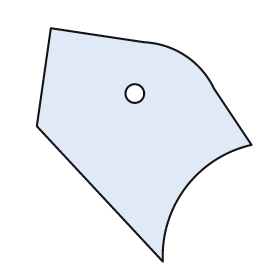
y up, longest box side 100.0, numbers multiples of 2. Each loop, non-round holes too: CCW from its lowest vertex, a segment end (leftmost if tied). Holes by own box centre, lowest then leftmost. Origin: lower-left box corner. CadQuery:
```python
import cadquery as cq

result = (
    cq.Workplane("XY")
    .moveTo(54.0, 0.0)
    .threePointArc((64.0, 32.0), (92.0, 50.0))
    .lineTo(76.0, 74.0)
    .threePointArc((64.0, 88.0), (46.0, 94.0))
    .lineTo(6.0, 100.0)
    .lineTo(0.0, 58.0)
    .close()
    .moveTo(42.0, 72.0)
    .circle(4.0)
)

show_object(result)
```